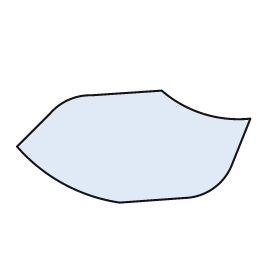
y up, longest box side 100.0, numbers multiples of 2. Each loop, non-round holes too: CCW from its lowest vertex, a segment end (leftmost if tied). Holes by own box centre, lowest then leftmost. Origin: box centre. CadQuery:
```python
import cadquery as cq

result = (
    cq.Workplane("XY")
    .moveTo(-6.0, -24.0)
    .lineTo(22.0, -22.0)
    .threePointArc((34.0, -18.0), (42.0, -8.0))
    .lineTo(50.0, 12.0)
    .threePointArc((30.0, 14.0), (12.0, 24.0))
    .lineTo(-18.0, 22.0)
    .threePointArc((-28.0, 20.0), (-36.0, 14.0))
    .lineTo(-50.0, 0.0)
    .threePointArc((-30.0, -16.0), (-6.0, -24.0))
    .close()
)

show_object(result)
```